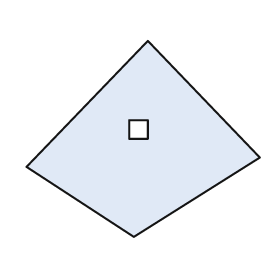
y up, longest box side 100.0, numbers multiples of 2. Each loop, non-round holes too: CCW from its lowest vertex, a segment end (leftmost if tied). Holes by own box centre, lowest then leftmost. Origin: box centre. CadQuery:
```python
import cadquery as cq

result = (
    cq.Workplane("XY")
    .moveTo(-4.0, -42.0)
    .lineTo(50.0, -8.0)
    .lineTo(2.0, 42.0)
    .lineTo(-50.0, -12.0)
    .close()
    .moveTo(-6.0, 0.0)
    .lineTo(2.0, 0.0)
    .lineTo(2.0, 8.0)
    .lineTo(-6.0, 8.0)
    .close()
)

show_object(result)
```